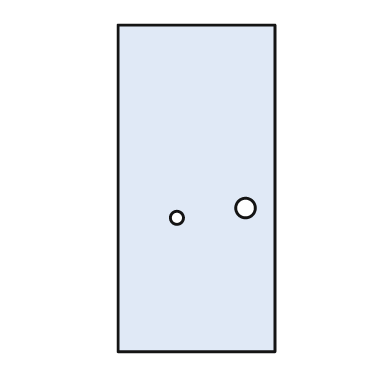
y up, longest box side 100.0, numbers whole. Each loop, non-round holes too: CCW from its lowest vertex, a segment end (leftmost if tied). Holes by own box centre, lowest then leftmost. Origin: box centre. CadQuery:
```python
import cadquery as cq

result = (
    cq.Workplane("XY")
    .moveTo(-24.0, -50.0)
    .lineTo(24.0, -50.0)
    .lineTo(24.0, 50.0)
    .lineTo(-24.0, 50.0)
    .close()
    .moveTo(-6.0, -9.0)
    .circle(2.0)
    .moveTo(15.0, -6.0)
    .circle(3.0)
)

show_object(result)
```